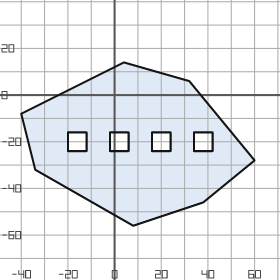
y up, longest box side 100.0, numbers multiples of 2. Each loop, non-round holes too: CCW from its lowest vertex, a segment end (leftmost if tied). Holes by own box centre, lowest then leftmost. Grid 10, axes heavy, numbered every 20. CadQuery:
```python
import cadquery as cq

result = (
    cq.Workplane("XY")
    .moveTo(8.0, -56.0)
    .lineTo(38.0, -46.0)
    .lineTo(60.0, -28.0)
    .lineTo(32.0, 6.0)
    .lineTo(4.0, 14.0)
    .lineTo(-40.0, -8.0)
    .lineTo(-34.0, -32.0)
    .close()
    .moveTo(-20.0, -24.0)
    .lineTo(-12.0, -24.0)
    .lineTo(-12.0, -16.0)
    .lineTo(-20.0, -16.0)
    .close()
    .moveTo(-2.0, -24.0)
    .lineTo(6.0, -24.0)
    .lineTo(6.0, -16.0)
    .lineTo(-2.0, -16.0)
    .close()
    .moveTo(16.0, -24.0)
    .lineTo(24.0, -24.0)
    .lineTo(24.0, -16.0)
    .lineTo(16.0, -16.0)
    .close()
    .moveTo(34.0, -24.0)
    .lineTo(42.0, -24.0)
    .lineTo(42.0, -16.0)
    .lineTo(34.0, -16.0)
    .close()
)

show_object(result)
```